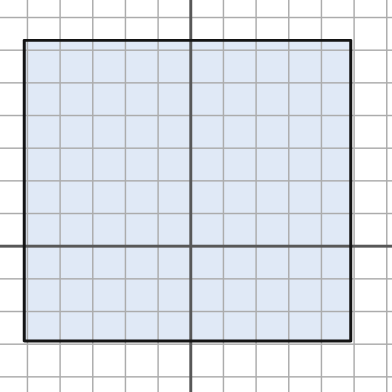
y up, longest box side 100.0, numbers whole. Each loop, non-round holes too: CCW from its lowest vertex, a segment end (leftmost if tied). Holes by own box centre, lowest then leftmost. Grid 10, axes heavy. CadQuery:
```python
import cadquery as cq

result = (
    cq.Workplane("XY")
    .moveTo(-51.0, -29.0)
    .lineTo(49.0, -29.0)
    .lineTo(49.0, 63.0)
    .lineTo(-51.0, 63.0)
    .close()
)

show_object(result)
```